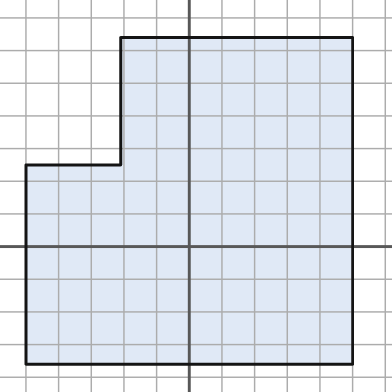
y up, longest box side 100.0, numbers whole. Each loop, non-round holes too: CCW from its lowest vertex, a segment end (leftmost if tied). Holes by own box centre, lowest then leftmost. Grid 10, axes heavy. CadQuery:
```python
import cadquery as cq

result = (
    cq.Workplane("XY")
    .moveTo(-50.0, -36.0)
    .lineTo(50.0, -36.0)
    .lineTo(50.0, 64.0)
    .lineTo(-21.0, 64.0)
    .lineTo(-21.0, 25.0)
    .lineTo(-50.0, 25.0)
    .close()
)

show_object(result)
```